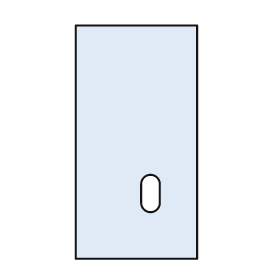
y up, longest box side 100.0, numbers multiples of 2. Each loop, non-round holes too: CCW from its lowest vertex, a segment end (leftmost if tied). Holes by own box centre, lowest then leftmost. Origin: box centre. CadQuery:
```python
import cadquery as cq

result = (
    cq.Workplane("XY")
    .moveTo(-26.0, -50.0)
    .lineTo(26.0, -50.0)
    .lineTo(26.0, 50.0)
    .lineTo(-26.0, 50.0)
    .close()
    .moveTo(2.0, -26.0)
    .threePointArc((6.0, -30.0), (10.0, -26.0))
    .lineTo(10.0, -18.0)
    .threePointArc((6.0, -14.0), (2.0, -18.0))
    .close()
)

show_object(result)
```